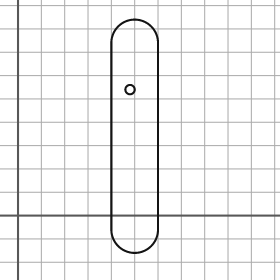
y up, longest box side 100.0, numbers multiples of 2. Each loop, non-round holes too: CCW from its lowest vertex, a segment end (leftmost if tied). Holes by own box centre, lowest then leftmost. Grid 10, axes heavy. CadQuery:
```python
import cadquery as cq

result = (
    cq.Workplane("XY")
    .moveTo(40.0, -6.0)
    .threePointArc((50.0, -16.0), (60.0, -6.0))
    .lineTo(60.0, 74.0)
    .threePointArc((50.0, 84.0), (40.0, 74.0))
    .close()
    .moveTo(48.0, 54.0)
    .circle(2.0)
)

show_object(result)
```